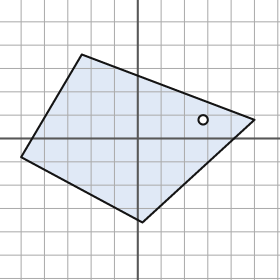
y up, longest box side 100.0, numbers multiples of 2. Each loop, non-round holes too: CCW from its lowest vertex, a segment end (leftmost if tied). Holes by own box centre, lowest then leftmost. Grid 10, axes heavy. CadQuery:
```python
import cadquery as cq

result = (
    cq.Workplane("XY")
    .moveTo(2.0, -36.0)
    .lineTo(50.0, 8.0)
    .lineTo(-24.0, 36.0)
    .lineTo(-50.0, -8.0)
    .close()
    .moveTo(28.0, 8.0)
    .circle(2.0)
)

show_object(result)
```